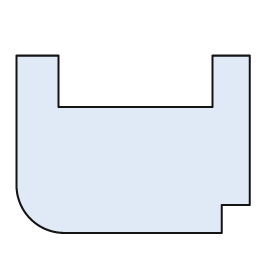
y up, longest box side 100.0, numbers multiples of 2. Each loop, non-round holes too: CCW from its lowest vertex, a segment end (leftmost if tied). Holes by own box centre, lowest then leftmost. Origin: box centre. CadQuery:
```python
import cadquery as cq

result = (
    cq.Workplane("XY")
    .moveTo(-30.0, -38.0)
    .lineTo(38.0, -38.0)
    .lineTo(38.0, -26.0)
    .lineTo(50.0, -26.0)
    .lineTo(50.0, 38.0)
    .lineTo(34.0, 38.0)
    .lineTo(34.0, 16.0)
    .lineTo(-32.0, 16.0)
    .lineTo(-32.0, 38.0)
    .lineTo(-50.0, 38.0)
    .lineTo(-50.0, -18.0)
    .threePointArc((-44.0, -32.0), (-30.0, -38.0))
    .close()
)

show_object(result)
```